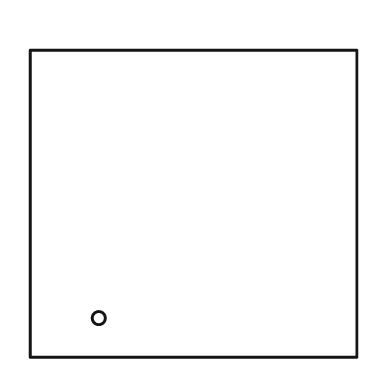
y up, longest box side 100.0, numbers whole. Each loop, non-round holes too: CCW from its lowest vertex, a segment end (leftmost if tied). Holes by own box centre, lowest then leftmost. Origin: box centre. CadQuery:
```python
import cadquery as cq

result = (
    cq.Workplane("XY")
    .moveTo(-50.0, -47.0)
    .lineTo(50.0, -47.0)
    .lineTo(50.0, 47.0)
    .lineTo(-50.0, 47.0)
    .close()
    .moveTo(-29.0, -35.0)
    .circle(2.0)
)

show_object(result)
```